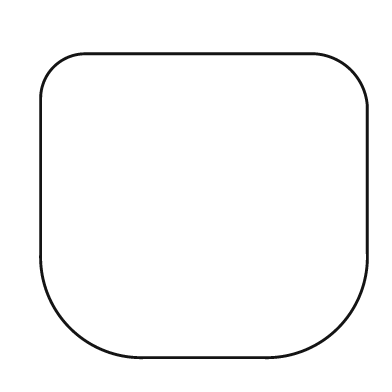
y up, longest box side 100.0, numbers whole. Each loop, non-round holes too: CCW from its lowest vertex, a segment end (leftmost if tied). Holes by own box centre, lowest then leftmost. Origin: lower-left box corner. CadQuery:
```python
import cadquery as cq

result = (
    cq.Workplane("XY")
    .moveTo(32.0, 0.0)
    .lineTo(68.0, 0.0)
    .threePointArc((91.0, 9.0), (100.0, 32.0))
    .lineTo(100.0, 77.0)
    .threePointArc((95.0, 88.0), (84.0, 93.0))
    .lineTo(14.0, 93.0)
    .threePointArc((4.0, 89.0), (0.0, 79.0))
    .lineTo(0.0, 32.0)
    .threePointArc((9.0, 9.0), (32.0, 0.0))
    .close()
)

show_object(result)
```